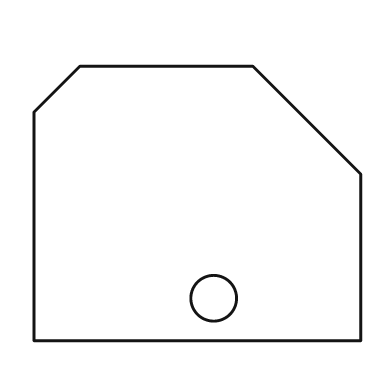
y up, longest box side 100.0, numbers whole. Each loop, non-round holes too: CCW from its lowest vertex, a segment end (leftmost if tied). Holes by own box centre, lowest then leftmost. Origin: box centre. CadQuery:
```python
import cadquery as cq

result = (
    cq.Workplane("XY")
    .moveTo(-50.0, -42.0)
    .lineTo(50.0, -42.0)
    .lineTo(50.0, 9.0)
    .lineTo(17.0, 42.0)
    .lineTo(-36.0, 42.0)
    .lineTo(-50.0, 28.0)
    .close()
    .moveTo(5.0, -29.0)
    .circle(7.0)
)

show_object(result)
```